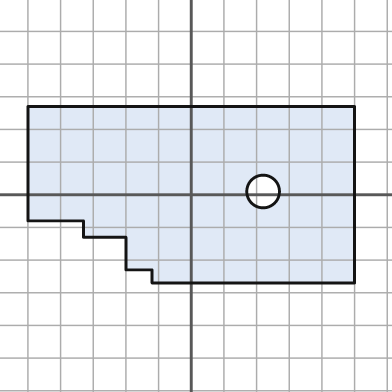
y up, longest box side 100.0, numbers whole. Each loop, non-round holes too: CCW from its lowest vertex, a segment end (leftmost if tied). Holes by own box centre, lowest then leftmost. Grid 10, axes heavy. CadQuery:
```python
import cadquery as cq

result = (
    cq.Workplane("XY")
    .moveTo(-12.0, -27.0)
    .lineTo(50.0, -27.0)
    .lineTo(50.0, 27.0)
    .lineTo(-50.0, 27.0)
    .lineTo(-50.0, -8.0)
    .lineTo(-33.0, -8.0)
    .lineTo(-33.0, -13.0)
    .lineTo(-20.0, -13.0)
    .lineTo(-20.0, -23.0)
    .lineTo(-12.0, -23.0)
    .close()
    .moveTo(22.0, 1.0)
    .circle(5.0)
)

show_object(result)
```